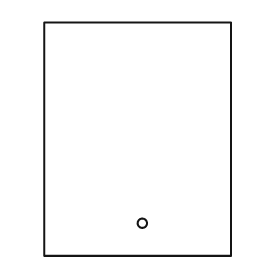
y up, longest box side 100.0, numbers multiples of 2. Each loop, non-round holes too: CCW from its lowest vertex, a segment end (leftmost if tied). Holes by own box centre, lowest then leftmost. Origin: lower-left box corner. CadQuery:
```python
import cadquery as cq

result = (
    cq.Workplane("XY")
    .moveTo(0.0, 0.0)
    .lineTo(80.0, 0.0)
    .lineTo(80.0, 100.0)
    .lineTo(0.0, 100.0)
    .close()
    .moveTo(42.0, 14.0)
    .circle(2.0)
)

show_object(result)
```